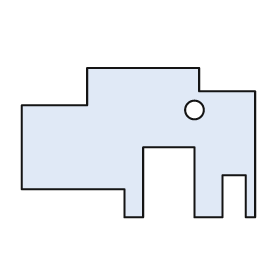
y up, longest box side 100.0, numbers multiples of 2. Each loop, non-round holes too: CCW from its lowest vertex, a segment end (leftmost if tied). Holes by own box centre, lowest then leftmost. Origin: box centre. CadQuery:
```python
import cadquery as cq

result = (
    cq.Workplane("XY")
    .moveTo(-6.0, -32.0)
    .lineTo(2.0, -32.0)
    .lineTo(2.0, -2.0)
    .lineTo(24.0, -2.0)
    .lineTo(24.0, -32.0)
    .lineTo(36.0, -32.0)
    .lineTo(36.0, -14.0)
    .lineTo(46.0, -14.0)
    .lineTo(46.0, -32.0)
    .lineTo(50.0, -32.0)
    .lineTo(50.0, 22.0)
    .lineTo(26.0, 22.0)
    .lineTo(26.0, 32.0)
    .lineTo(-22.0, 32.0)
    .lineTo(-22.0, 16.0)
    .lineTo(-50.0, 16.0)
    .lineTo(-50.0, -20.0)
    .lineTo(-6.0, -20.0)
    .close()
    .moveTo(24.0, 14.0)
    .circle(4.0)
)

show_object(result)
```